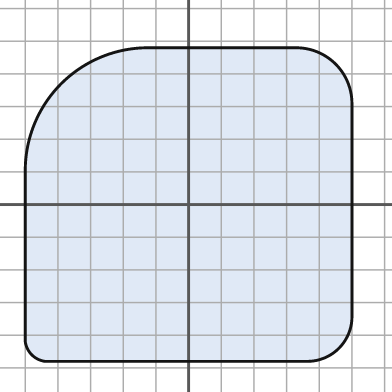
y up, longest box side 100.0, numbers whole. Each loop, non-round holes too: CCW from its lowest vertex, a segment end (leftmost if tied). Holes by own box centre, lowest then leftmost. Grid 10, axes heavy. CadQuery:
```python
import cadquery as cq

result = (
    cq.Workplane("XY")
    .moveTo(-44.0, -48.0)
    .lineTo(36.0, -48.0)
    .threePointArc((46.0, -44.0), (50.0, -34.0))
    .lineTo(50.0, 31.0)
    .threePointArc((45.0, 43.0), (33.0, 48.0))
    .lineTo(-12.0, 48.0)
    .threePointArc((-39.0, 37.0), (-50.0, 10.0))
    .lineTo(-50.0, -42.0)
    .threePointArc((-48.0, -46.0), (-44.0, -48.0))
    .close()
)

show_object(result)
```